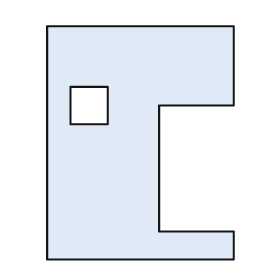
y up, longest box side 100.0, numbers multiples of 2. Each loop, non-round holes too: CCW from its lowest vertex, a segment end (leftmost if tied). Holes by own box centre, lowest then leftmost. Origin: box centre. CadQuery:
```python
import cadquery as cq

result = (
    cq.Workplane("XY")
    .moveTo(-40.0, -50.0)
    .lineTo(40.0, -50.0)
    .lineTo(40.0, -38.0)
    .lineTo(8.0, -38.0)
    .lineTo(8.0, 16.0)
    .lineTo(40.0, 16.0)
    .lineTo(40.0, 50.0)
    .lineTo(-40.0, 50.0)
    .close()
    .moveTo(-30.0, 8.0)
    .lineTo(-14.0, 8.0)
    .lineTo(-14.0, 24.0)
    .lineTo(-30.0, 24.0)
    .close()
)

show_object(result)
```